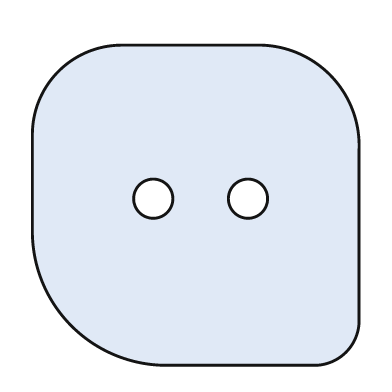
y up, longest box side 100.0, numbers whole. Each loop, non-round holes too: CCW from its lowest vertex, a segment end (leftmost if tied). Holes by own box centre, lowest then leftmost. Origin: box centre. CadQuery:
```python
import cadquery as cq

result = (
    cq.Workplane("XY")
    .moveTo(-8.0, -49.0)
    .lineTo(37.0, -49.0)
    .threePointArc((46.0, -45.0), (50.0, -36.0))
    .lineTo(50.0, 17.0)
    .threePointArc((41.0, 40.0), (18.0, 49.0))
    .lineTo(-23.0, 49.0)
    .threePointArc((-42.0, 41.0), (-50.0, 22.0))
    .lineTo(-50.0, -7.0)
    .threePointArc((-38.0, -37.0), (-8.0, -49.0))
    .close()
    .moveTo(-13.0, 2.0)
    .circle(6.0)
    .moveTo(16.0, 2.0)
    .circle(6.0)
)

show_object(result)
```